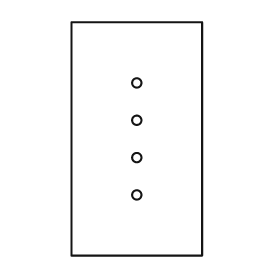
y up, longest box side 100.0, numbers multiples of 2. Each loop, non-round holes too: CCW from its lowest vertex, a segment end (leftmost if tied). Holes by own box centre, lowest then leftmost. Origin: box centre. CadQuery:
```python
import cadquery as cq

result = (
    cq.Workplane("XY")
    .moveTo(-28.0, -50.0)
    .lineTo(28.0, -50.0)
    .lineTo(28.0, 50.0)
    .lineTo(-28.0, 50.0)
    .close()
    .moveTo(0.0, -24.0)
    .circle(2.0)
    .moveTo(0.0, -8.0)
    .circle(2.0)
    .moveTo(0.0, 8.0)
    .circle(2.0)
    .moveTo(0.0, 24.0)
    .circle(2.0)
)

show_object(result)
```